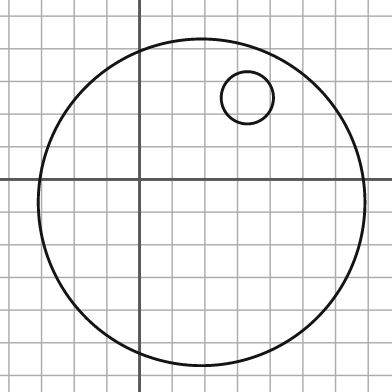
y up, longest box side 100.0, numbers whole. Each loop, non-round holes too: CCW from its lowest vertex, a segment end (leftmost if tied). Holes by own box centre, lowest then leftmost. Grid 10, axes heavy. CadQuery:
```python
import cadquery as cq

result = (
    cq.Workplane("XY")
    .moveTo(19.0, -7.0)
    .circle(50.0)
    .moveTo(33.0, 25.0)
    .circle(8.0)
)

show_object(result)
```